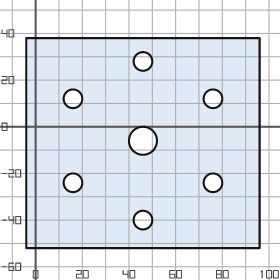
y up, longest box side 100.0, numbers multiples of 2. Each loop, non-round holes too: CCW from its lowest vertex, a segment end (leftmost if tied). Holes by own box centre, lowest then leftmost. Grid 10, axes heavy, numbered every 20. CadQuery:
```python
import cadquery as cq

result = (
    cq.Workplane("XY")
    .moveTo(-4.0, -52.0)
    .lineTo(96.0, -52.0)
    .lineTo(96.0, 38.0)
    .lineTo(-4.0, 38.0)
    .close()
    .moveTo(46.0, -40.0)
    .circle(4.0)
    .moveTo(16.0, -24.0)
    .circle(4.0)
    .moveTo(76.0, -24.0)
    .circle(4.0)
    .moveTo(46.0, -6.0)
    .circle(6.0)
    .moveTo(16.0, 12.0)
    .circle(4.0)
    .moveTo(76.0, 12.0)
    .circle(4.0)
    .moveTo(46.0, 28.0)
    .circle(4.0)
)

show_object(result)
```